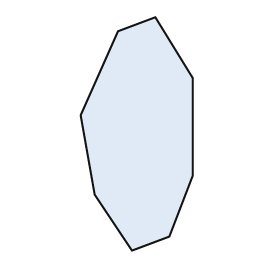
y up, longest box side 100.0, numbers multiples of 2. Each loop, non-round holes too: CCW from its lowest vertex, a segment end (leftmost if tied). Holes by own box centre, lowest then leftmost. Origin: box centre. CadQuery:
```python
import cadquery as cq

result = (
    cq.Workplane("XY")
    .moveTo(-2.0, -50.0)
    .lineTo(14.0, -44.0)
    .lineTo(24.0, -18.0)
    .lineTo(24.0, 24.0)
    .lineTo(8.0, 50.0)
    .lineTo(-8.0, 44.0)
    .lineTo(-24.0, 8.0)
    .lineTo(-18.0, -26.0)
    .close()
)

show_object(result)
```